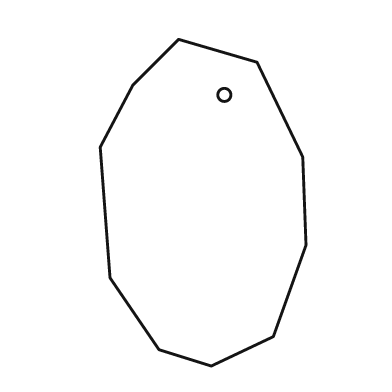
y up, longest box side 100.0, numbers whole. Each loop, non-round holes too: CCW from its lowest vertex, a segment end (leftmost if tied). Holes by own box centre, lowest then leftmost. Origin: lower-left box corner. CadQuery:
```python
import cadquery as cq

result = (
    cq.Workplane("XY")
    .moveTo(34.0, 0.0)
    .lineTo(53.0, 9.0)
    .lineTo(63.0, 37.0)
    .lineTo(62.0, 64.0)
    .lineTo(48.0, 93.0)
    .lineTo(24.0, 100.0)
    .lineTo(10.0, 86.0)
    .lineTo(0.0, 67.0)
    .lineTo(3.0, 27.0)
    .lineTo(18.0, 5.0)
    .close()
    .moveTo(38.0, 83.0)
    .circle(2.0)
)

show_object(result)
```